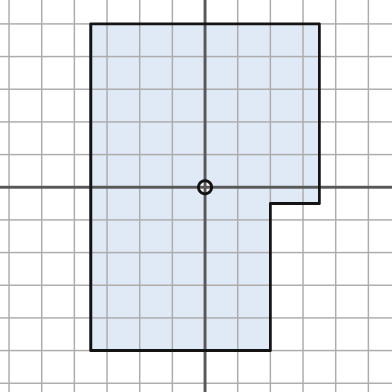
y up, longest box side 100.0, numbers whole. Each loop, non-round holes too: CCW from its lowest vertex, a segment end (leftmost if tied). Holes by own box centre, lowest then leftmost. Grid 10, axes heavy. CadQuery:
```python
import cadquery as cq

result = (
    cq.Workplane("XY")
    .moveTo(-35.0, -50.0)
    .lineTo(20.0, -50.0)
    .lineTo(20.0, -5.0)
    .lineTo(35.0, -5.0)
    .lineTo(35.0, 50.0)
    .lineTo(-35.0, 50.0)
    .close()
    .moveTo(0.0, 0.0)
    .circle(2.0)
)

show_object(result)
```